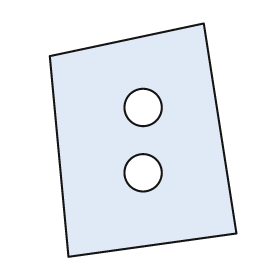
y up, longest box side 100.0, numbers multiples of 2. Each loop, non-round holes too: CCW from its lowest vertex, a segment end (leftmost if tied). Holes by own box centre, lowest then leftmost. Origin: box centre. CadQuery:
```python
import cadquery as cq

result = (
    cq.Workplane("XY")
    .moveTo(-32.0, -50.0)
    .lineTo(40.0, -40.0)
    .lineTo(26.0, 50.0)
    .lineTo(-40.0, 36.0)
    .close()
    .moveTo(0.0, -14.0)
    .circle(8.0)
    .moveTo(0.0, 14.0)
    .circle(8.0)
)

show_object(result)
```